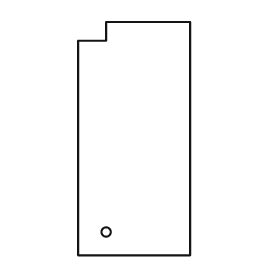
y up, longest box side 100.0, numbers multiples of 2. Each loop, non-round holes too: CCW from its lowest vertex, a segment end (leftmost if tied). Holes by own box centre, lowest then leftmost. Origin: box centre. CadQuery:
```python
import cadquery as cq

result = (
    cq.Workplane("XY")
    .moveTo(-24.0, -50.0)
    .lineTo(24.0, -50.0)
    .lineTo(24.0, 50.0)
    .lineTo(-12.0, 50.0)
    .lineTo(-12.0, 42.0)
    .lineTo(-24.0, 42.0)
    .close()
    .moveTo(-12.0, -40.0)
    .circle(2.0)
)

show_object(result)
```